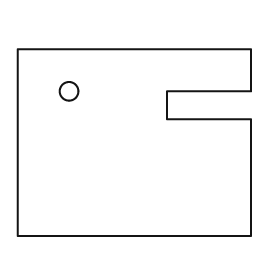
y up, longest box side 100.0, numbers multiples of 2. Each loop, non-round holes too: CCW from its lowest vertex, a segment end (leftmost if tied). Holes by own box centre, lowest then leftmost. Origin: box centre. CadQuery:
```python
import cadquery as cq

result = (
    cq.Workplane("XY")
    .moveTo(-50.0, -40.0)
    .lineTo(50.0, -40.0)
    .lineTo(50.0, 10.0)
    .lineTo(14.0, 10.0)
    .lineTo(14.0, 22.0)
    .lineTo(50.0, 22.0)
    .lineTo(50.0, 40.0)
    .lineTo(-50.0, 40.0)
    .close()
    .moveTo(-28.0, 22.0)
    .circle(4.0)
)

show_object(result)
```